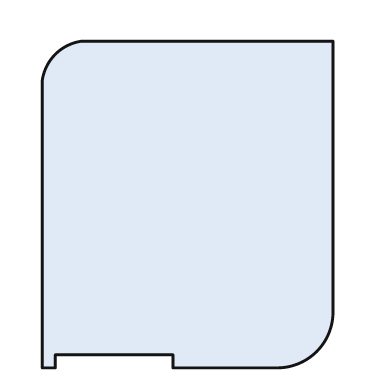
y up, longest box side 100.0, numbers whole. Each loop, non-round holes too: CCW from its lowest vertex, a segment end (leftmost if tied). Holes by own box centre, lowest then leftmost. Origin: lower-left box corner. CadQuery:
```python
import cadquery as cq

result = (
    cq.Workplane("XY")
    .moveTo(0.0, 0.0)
    .lineTo(4.0, 0.0)
    .lineTo(4.0, 4.0)
    .lineTo(40.0, 4.0)
    .lineTo(40.0, 0.0)
    .lineTo(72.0, 0.0)
    .threePointArc((84.0, 5.0), (89.0, 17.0))
    .lineTo(89.0, 100.0)
    .lineTo(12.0, 100.0)
    .threePointArc((4.0, 96.0), (0.0, 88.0))
    .close()
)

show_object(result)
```